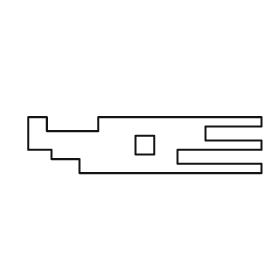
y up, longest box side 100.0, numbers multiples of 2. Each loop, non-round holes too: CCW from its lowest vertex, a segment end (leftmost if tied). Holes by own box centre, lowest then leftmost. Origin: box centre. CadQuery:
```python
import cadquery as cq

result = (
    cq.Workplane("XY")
    .moveTo(-28.0, -12.0)
    .lineTo(50.0, -12.0)
    .lineTo(50.0, -8.0)
    .lineTo(14.0, -8.0)
    .lineTo(14.0, -2.0)
    .lineTo(50.0, -2.0)
    .lineTo(50.0, 2.0)
    .lineTo(26.0, 2.0)
    .lineTo(26.0, 8.0)
    .lineTo(50.0, 8.0)
    .lineTo(50.0, 12.0)
    .lineTo(-20.0, 12.0)
    .lineTo(-20.0, 6.0)
    .lineTo(-42.0, 6.0)
    .lineTo(-42.0, 12.0)
    .lineTo(-50.0, 12.0)
    .lineTo(-50.0, -2.0)
    .lineTo(-40.0, -2.0)
    .lineTo(-40.0, -6.0)
    .lineTo(-28.0, -6.0)
    .close()
    .moveTo(-4.0, -4.0)
    .lineTo(4.0, -4.0)
    .lineTo(4.0, 4.0)
    .lineTo(-4.0, 4.0)
    .close()
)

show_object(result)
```